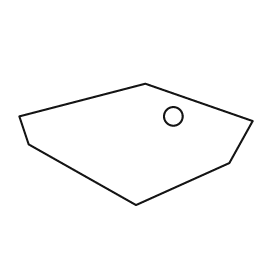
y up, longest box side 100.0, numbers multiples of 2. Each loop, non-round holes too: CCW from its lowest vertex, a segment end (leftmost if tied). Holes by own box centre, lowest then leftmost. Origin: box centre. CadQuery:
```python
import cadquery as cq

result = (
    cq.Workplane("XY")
    .moveTo(0.0, -26.0)
    .lineTo(40.0, -8.0)
    .lineTo(50.0, 10.0)
    .lineTo(4.0, 26.0)
    .lineTo(-50.0, 12.0)
    .lineTo(-46.0, 0.0)
    .close()
    .moveTo(16.0, 12.0)
    .circle(4.0)
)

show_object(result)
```